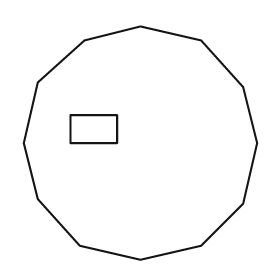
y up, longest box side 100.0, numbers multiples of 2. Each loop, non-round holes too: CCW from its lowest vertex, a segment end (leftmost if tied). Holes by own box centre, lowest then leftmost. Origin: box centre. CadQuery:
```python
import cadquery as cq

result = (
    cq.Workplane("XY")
    .moveTo(0.0, -50.0)
    .lineTo(26.0, -44.0)
    .lineTo(44.0, -26.0)
    .lineTo(50.0, 0.0)
    .lineTo(44.0, 24.0)
    .lineTo(26.0, 44.0)
    .lineTo(0.0, 50.0)
    .lineTo(-24.0, 44.0)
    .lineTo(-44.0, 26.0)
    .lineTo(-50.0, 0.0)
    .lineTo(-44.0, -24.0)
    .lineTo(-26.0, -44.0)
    .close()
    .moveTo(-30.0, 0.0)
    .lineTo(-10.0, 0.0)
    .lineTo(-10.0, 12.0)
    .lineTo(-30.0, 12.0)
    .close()
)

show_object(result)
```